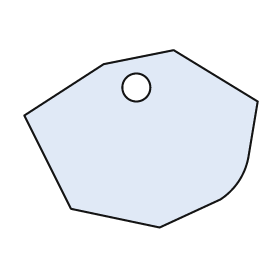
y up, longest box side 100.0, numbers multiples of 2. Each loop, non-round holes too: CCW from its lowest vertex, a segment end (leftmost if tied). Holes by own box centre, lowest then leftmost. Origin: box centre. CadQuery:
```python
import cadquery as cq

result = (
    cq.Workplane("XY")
    .moveTo(8.0, -38.0)
    .lineTo(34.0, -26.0)
    .threePointArc((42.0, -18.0), (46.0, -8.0))
    .lineTo(50.0, 16.0)
    .lineTo(14.0, 38.0)
    .lineTo(-16.0, 32.0)
    .lineTo(-50.0, 10.0)
    .lineTo(-30.0, -30.0)
    .close()
    .moveTo(-2.0, 22.0)
    .circle(6.0)
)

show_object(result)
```